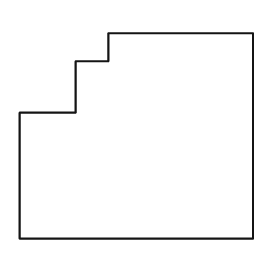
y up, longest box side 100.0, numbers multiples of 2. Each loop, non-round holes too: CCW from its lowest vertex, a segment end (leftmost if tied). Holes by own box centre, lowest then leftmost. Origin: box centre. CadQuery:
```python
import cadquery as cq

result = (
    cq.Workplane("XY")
    .moveTo(-50.0, -44.0)
    .lineTo(50.0, -44.0)
    .lineTo(50.0, 44.0)
    .lineTo(-12.0, 44.0)
    .lineTo(-12.0, 32.0)
    .lineTo(-26.0, 32.0)
    .lineTo(-26.0, 10.0)
    .lineTo(-50.0, 10.0)
    .close()
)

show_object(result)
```